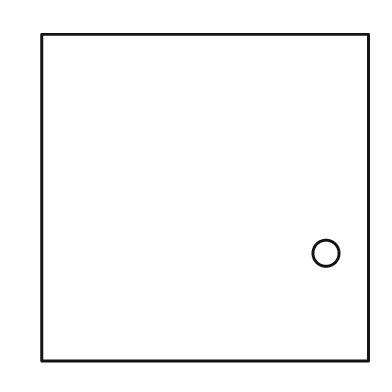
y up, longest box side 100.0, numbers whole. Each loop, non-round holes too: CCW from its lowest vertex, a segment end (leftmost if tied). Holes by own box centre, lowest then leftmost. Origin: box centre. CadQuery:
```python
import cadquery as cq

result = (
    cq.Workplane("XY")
    .moveTo(-50.0, -50.0)
    .lineTo(50.0, -50.0)
    .lineTo(50.0, 50.0)
    .lineTo(-50.0, 50.0)
    .close()
    .moveTo(37.0, -17.0)
    .circle(4.0)
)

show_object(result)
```